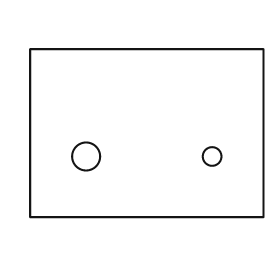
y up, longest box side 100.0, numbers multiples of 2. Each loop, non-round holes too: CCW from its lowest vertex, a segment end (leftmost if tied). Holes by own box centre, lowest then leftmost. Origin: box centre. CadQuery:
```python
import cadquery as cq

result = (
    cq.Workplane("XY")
    .moveTo(-50.0, -36.0)
    .lineTo(50.0, -36.0)
    .lineTo(50.0, 36.0)
    .lineTo(-50.0, 36.0)
    .close()
    .moveTo(-26.0, -10.0)
    .circle(6.0)
    .moveTo(28.0, -10.0)
    .circle(4.0)
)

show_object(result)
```